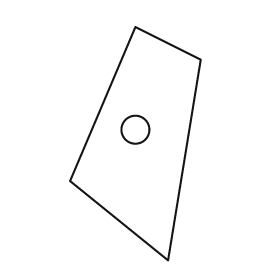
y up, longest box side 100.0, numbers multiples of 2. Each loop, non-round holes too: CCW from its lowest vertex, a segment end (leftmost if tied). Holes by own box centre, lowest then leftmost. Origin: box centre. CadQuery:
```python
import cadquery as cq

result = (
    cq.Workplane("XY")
    .moveTo(14.0, -50.0)
    .lineTo(28.0, 36.0)
    .lineTo(0.0, 50.0)
    .lineTo(-28.0, -16.0)
    .close()
    .moveTo(0.0, 6.0)
    .circle(6.0)
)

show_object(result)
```